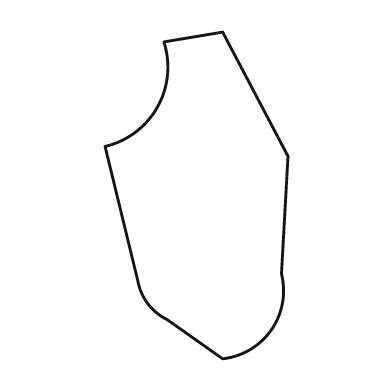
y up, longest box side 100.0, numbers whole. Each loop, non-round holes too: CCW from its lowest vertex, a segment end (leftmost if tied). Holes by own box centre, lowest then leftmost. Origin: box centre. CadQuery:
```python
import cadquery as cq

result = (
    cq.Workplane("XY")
    .moveTo(8.0, -50.0)
    .threePointArc((23.0, -41.0), (26.0, -24.0))
    .lineTo(28.0, 12.0)
    .lineTo(8.0, 50.0)
    .lineTo(-10.0, 47.0)
    .threePointArc((-12.0, 27.0), (-28.0, 15.0))
    .lineTo(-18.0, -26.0)
    .threePointArc((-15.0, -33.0), (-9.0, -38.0))
    .close()
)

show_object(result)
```